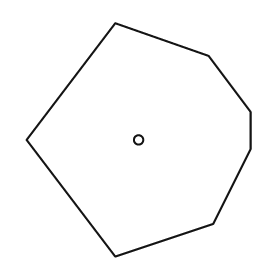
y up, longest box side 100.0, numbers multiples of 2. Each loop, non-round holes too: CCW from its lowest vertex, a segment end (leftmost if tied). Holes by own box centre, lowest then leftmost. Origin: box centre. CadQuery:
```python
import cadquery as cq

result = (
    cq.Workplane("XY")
    .moveTo(-10.0, -50.0)
    .lineTo(32.0, -36.0)
    .lineTo(48.0, -4.0)
    .lineTo(48.0, 12.0)
    .lineTo(30.0, 36.0)
    .lineTo(-10.0, 50.0)
    .lineTo(-48.0, 0.0)
    .close()
    .moveTo(0.0, 0.0)
    .circle(2.0)
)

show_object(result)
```